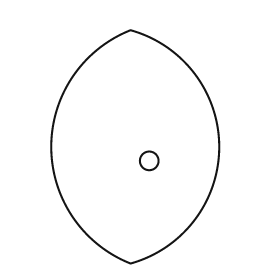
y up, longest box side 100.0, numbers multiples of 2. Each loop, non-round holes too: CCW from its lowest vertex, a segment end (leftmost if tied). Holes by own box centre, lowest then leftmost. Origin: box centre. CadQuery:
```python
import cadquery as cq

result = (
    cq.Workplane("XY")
    .moveTo(-2.0, -50.0)
    .threePointArc((36.0, 0.0), (-2.0, 50.0))
    .threePointArc((-36.0, 0.0), (-2.0, -50.0))
    .close()
    .moveTo(6.0, -6.0)
    .circle(4.0)
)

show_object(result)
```